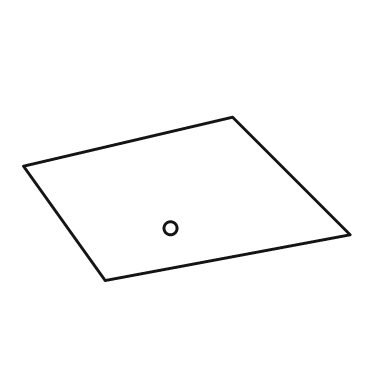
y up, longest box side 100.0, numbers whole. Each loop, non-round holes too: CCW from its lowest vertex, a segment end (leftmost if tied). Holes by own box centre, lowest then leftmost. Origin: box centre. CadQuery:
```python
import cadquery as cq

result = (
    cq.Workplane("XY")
    .moveTo(-25.0, -25.0)
    .lineTo(50.0, -11.0)
    .lineTo(14.0, 25.0)
    .lineTo(-50.0, 10.0)
    .close()
    .moveTo(-5.0, -9.0)
    .circle(2.0)
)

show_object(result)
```